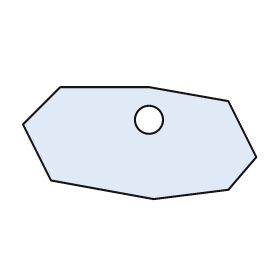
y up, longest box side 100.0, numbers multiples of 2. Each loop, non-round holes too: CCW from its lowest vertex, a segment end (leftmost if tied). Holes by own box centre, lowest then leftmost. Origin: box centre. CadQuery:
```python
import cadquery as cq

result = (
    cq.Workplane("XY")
    .moveTo(6.0, -24.0)
    .lineTo(38.0, -20.0)
    .lineTo(50.0, -6.0)
    .lineTo(38.0, 18.0)
    .lineTo(4.0, 24.0)
    .lineTo(-34.0, 24.0)
    .lineTo(-50.0, 8.0)
    .lineTo(-38.0, -16.0)
    .close()
    .moveTo(4.0, 10.0)
    .circle(6.0)
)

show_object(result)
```